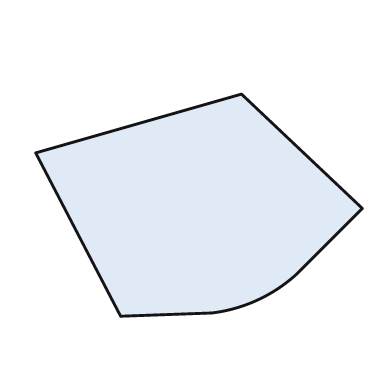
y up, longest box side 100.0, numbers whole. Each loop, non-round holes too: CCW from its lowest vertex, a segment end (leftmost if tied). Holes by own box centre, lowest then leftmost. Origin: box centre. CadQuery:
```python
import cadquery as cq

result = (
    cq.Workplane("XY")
    .moveTo(-24.0, -34.0)
    .lineTo(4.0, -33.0)
    .threePointArc((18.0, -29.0), (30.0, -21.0))
    .lineTo(50.0, -1.0)
    .lineTo(13.0, 34.0)
    .lineTo(-50.0, 16.0)
    .close()
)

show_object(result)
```